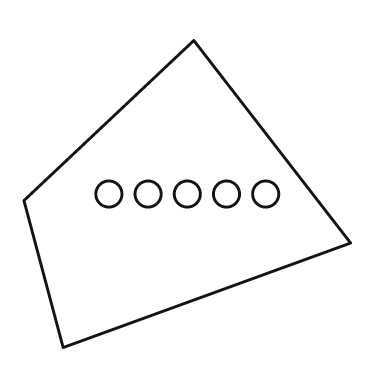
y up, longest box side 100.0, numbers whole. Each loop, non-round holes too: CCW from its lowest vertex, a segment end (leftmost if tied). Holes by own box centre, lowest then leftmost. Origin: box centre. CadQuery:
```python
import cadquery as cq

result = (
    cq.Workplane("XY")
    .moveTo(-38.0, -47.0)
    .lineTo(50.0, -15.0)
    .lineTo(2.0, 47.0)
    .lineTo(-50.0, -2.0)
    .close()
    .moveTo(-24.0, 0.0)
    .circle(4.0)
    .moveTo(-12.0, 0.0)
    .circle(4.0)
    .moveTo(0.0, 0.0)
    .circle(4.0)
    .moveTo(12.0, 0.0)
    .circle(4.0)
    .moveTo(24.0, 0.0)
    .circle(4.0)
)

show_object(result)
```